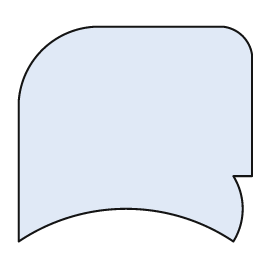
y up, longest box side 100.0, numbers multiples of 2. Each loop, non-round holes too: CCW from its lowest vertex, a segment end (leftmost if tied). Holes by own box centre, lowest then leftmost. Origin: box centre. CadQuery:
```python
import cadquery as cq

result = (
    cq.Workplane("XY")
    .moveTo(-50.0, -46.0)
    .threePointArc((-4.0, -32.0), (42.0, -46.0))
    .threePointArc((46.0, -32.0), (42.0, -18.0))
    .lineTo(50.0, -18.0)
    .lineTo(50.0, 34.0)
    .threePointArc((46.0, 42.0), (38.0, 46.0))
    .lineTo(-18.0, 46.0)
    .threePointArc((-40.0, 36.0), (-50.0, 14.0))
    .close()
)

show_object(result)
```